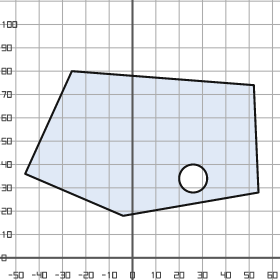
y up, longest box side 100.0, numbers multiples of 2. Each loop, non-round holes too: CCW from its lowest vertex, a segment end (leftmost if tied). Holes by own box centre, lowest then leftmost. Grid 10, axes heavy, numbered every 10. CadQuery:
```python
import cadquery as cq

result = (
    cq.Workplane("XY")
    .moveTo(-4.0, 18.0)
    .lineTo(54.0, 28.0)
    .lineTo(52.0, 74.0)
    .lineTo(-26.0, 80.0)
    .lineTo(-46.0, 36.0)
    .close()
    .moveTo(26.0, 34.0)
    .circle(6.0)
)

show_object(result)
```